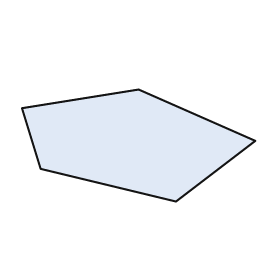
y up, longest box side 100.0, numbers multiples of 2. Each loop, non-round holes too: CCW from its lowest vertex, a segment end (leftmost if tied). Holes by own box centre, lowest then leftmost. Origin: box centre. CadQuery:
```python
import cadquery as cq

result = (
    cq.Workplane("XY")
    .moveTo(16.0, -24.0)
    .lineTo(50.0, 2.0)
    .lineTo(0.0, 24.0)
    .lineTo(-50.0, 16.0)
    .lineTo(-42.0, -10.0)
    .close()
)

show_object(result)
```